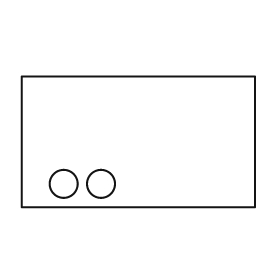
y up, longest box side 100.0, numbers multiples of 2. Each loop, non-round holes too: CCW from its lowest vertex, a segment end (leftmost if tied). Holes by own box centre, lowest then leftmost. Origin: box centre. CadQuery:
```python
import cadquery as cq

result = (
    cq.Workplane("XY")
    .moveTo(-50.0, -28.0)
    .lineTo(50.0, -28.0)
    .lineTo(50.0, 28.0)
    .lineTo(-50.0, 28.0)
    .close()
    .moveTo(-32.0, -18.0)
    .circle(6.0)
    .moveTo(-16.0, -18.0)
    .circle(6.0)
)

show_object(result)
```